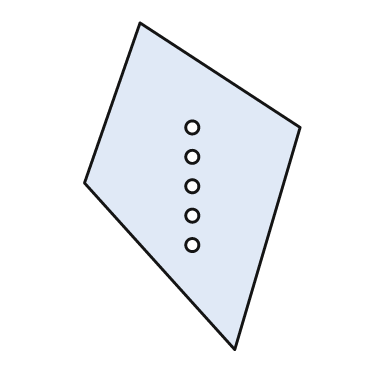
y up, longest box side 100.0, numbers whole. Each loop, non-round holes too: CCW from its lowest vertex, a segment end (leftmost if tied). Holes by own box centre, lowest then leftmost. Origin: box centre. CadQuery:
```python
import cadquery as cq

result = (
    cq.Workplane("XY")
    .moveTo(13.0, -50.0)
    .lineTo(33.0, 18.0)
    .lineTo(-16.0, 50.0)
    .lineTo(-33.0, 1.0)
    .close()
    .moveTo(0.0, -18.0)
    .circle(2.0)
    .moveTo(0.0, -9.0)
    .circle(2.0)
    .moveTo(0.0, 0.0)
    .circle(2.0)
    .moveTo(0.0, 9.0)
    .circle(2.0)
    .moveTo(0.0, 18.0)
    .circle(2.0)
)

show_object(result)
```